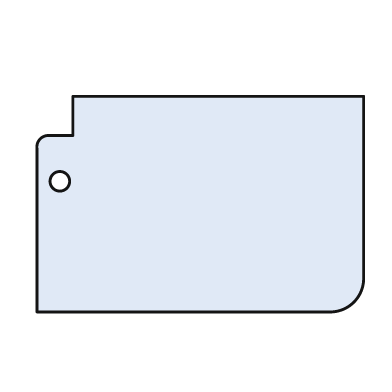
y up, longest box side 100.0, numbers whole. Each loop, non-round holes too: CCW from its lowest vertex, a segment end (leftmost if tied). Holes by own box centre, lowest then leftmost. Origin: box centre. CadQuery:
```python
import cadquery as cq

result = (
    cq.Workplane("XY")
    .moveTo(-50.0, -33.0)
    .lineTo(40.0, -33.0)
    .threePointArc((47.0, -30.0), (50.0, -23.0))
    .lineTo(50.0, 33.0)
    .lineTo(-39.0, 33.0)
    .lineTo(-39.0, 21.0)
    .lineTo(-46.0, 21.0)
    .threePointArc((-49.0, 20.0), (-50.0, 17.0))
    .close()
    .moveTo(-43.0, 7.0)
    .circle(3.0)
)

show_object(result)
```